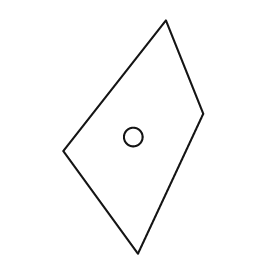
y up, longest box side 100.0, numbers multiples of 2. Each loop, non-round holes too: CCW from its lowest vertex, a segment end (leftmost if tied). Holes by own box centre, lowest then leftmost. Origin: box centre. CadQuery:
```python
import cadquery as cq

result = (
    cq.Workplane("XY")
    .moveTo(2.0, -50.0)
    .lineTo(30.0, 10.0)
    .lineTo(14.0, 50.0)
    .lineTo(-30.0, -6.0)
    .close()
    .moveTo(0.0, 0.0)
    .circle(4.0)
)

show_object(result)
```